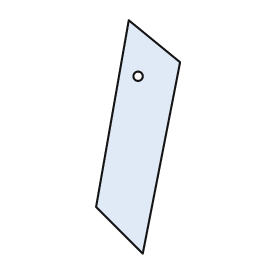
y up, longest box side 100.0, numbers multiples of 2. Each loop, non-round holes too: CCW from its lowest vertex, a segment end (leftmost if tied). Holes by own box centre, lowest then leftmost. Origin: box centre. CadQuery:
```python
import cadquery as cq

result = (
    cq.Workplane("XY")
    .moveTo(2.0, -50.0)
    .lineTo(18.0, 32.0)
    .lineTo(-4.0, 50.0)
    .lineTo(-18.0, -30.0)
    .close()
    .moveTo(0.0, 26.0)
    .circle(2.0)
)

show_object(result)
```